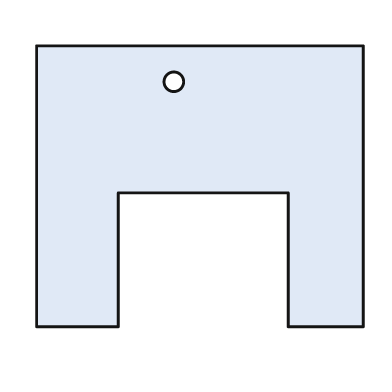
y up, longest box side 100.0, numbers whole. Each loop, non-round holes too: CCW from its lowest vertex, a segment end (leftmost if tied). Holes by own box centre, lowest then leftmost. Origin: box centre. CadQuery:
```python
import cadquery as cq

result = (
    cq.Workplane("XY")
    .moveTo(-50.0, -43.0)
    .lineTo(-25.0, -43.0)
    .lineTo(-25.0, -2.0)
    .lineTo(27.0, -2.0)
    .lineTo(27.0, -43.0)
    .lineTo(50.0, -43.0)
    .lineTo(50.0, 43.0)
    .lineTo(-50.0, 43.0)
    .close()
    .moveTo(-8.0, 32.0)
    .circle(3.0)
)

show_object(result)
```